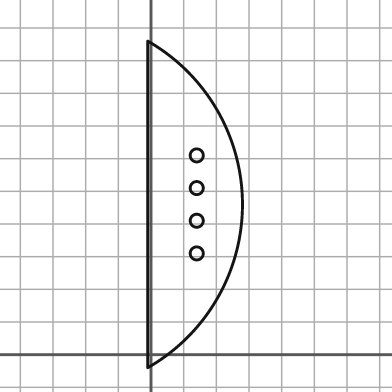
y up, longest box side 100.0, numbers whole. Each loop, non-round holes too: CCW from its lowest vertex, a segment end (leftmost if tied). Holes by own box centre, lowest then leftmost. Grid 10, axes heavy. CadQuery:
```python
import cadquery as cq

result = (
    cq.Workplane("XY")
    .moveTo(-1.0, -4.0)
    .threePointArc((28.0, 46.0), (-1.0, 96.0))
    .close()
    .moveTo(14.0, 31.0)
    .circle(2.0)
    .moveTo(14.0, 41.0)
    .circle(2.0)
    .moveTo(14.0, 51.0)
    .circle(2.0)
    .moveTo(14.0, 61.0)
    .circle(2.0)
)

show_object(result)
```